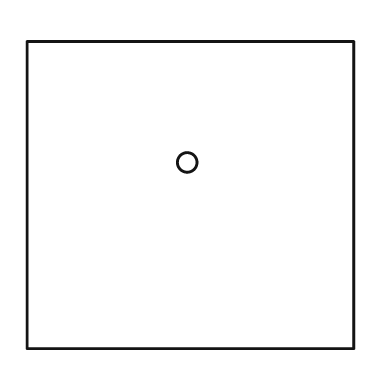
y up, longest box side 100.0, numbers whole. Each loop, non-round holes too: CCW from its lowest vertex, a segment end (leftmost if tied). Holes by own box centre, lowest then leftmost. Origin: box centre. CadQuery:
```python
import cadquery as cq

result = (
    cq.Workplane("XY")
    .moveTo(-50.0, -47.0)
    .lineTo(50.0, -47.0)
    .lineTo(50.0, 47.0)
    .lineTo(-50.0, 47.0)
    .close()
    .moveTo(-1.0, 10.0)
    .circle(3.0)
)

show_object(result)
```